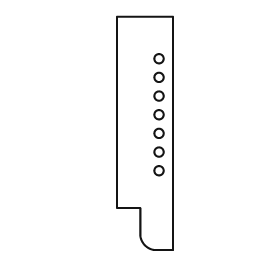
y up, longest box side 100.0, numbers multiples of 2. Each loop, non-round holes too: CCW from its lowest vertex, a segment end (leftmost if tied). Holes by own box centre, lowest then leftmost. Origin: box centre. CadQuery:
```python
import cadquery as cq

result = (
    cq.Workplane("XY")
    .moveTo(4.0, -50.0)
    .lineTo(12.0, -50.0)
    .lineTo(12.0, 50.0)
    .lineTo(-12.0, 50.0)
    .lineTo(-12.0, -32.0)
    .lineTo(-2.0, -32.0)
    .lineTo(-2.0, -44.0)
    .threePointArc((0.0, -48.0), (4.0, -50.0))
    .close()
    .moveTo(6.0, -16.0)
    .circle(2.0)
    .moveTo(6.0, -8.0)
    .circle(2.0)
    .moveTo(6.0, 0.0)
    .circle(2.0)
    .moveTo(6.0, 8.0)
    .circle(2.0)
    .moveTo(6.0, 16.0)
    .circle(2.0)
    .moveTo(6.0, 24.0)
    .circle(2.0)
    .moveTo(6.0, 32.0)
    .circle(2.0)
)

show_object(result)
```